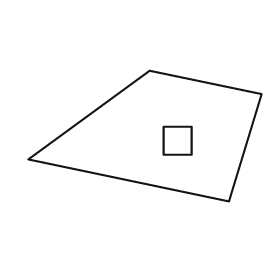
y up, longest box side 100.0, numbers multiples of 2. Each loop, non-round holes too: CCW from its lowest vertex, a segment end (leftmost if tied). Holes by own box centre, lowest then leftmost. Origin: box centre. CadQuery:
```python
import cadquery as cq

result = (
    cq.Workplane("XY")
    .moveTo(36.0, -28.0)
    .lineTo(50.0, 18.0)
    .lineTo(2.0, 28.0)
    .lineTo(-50.0, -10.0)
    .close()
    .moveTo(8.0, -8.0)
    .lineTo(20.0, -8.0)
    .lineTo(20.0, 4.0)
    .lineTo(8.0, 4.0)
    .close()
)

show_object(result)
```